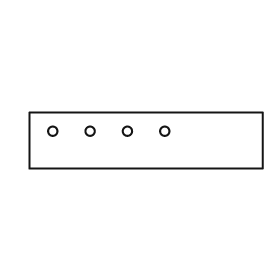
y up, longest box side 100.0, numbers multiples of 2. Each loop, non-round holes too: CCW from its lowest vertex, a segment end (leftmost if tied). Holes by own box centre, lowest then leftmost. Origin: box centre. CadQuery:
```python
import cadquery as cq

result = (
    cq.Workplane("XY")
    .moveTo(-50.0, -12.0)
    .lineTo(50.0, -12.0)
    .lineTo(50.0, 12.0)
    .lineTo(-50.0, 12.0)
    .close()
    .moveTo(-40.0, 4.0)
    .circle(2.0)
    .moveTo(-24.0, 4.0)
    .circle(2.0)
    .moveTo(-8.0, 4.0)
    .circle(2.0)
    .moveTo(8.0, 4.0)
    .circle(2.0)
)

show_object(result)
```